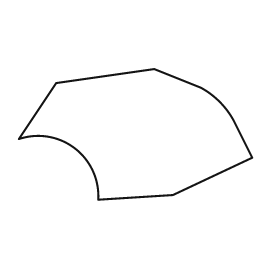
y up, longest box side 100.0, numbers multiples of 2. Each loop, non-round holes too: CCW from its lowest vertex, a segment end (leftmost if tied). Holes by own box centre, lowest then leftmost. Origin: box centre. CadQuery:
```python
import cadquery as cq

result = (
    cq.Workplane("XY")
    .moveTo(-16.0, -28.0)
    .lineTo(16.0, -26.0)
    .lineTo(50.0, -10.0)
    .lineTo(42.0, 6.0)
    .threePointArc((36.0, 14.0), (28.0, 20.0))
    .lineTo(8.0, 28.0)
    .lineTo(-34.0, 22.0)
    .lineTo(-50.0, -2.0)
    .threePointArc((-26.0, -6.0), (-16.0, -28.0))
    .close()
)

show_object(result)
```